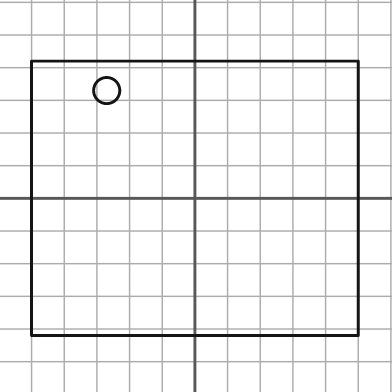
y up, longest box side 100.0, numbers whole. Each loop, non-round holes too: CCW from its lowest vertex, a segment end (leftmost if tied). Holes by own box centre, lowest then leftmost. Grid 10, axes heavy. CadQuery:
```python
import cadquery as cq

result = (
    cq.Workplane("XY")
    .moveTo(-50.0, -42.0)
    .lineTo(50.0, -42.0)
    .lineTo(50.0, 42.0)
    .lineTo(-50.0, 42.0)
    .close()
    .moveTo(-27.0, 33.0)
    .circle(4.0)
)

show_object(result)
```